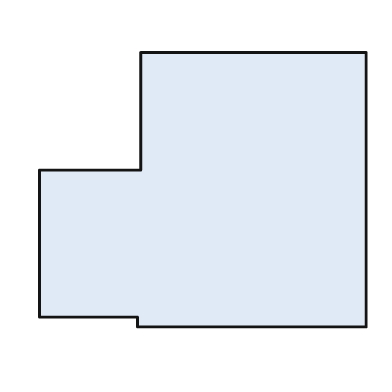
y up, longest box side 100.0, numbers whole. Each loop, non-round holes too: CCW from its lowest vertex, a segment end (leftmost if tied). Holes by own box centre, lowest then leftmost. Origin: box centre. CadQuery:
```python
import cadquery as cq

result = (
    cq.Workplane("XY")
    .moveTo(-20.0, -42.0)
    .lineTo(50.0, -42.0)
    .lineTo(50.0, 42.0)
    .lineTo(-19.0, 42.0)
    .lineTo(-19.0, 6.0)
    .lineTo(-50.0, 6.0)
    .lineTo(-50.0, -39.0)
    .lineTo(-20.0, -39.0)
    .close()
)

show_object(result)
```